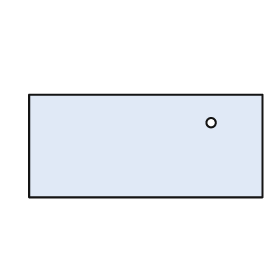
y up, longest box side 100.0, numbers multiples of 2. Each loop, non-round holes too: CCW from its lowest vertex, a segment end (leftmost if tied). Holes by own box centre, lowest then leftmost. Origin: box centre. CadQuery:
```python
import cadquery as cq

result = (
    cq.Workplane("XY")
    .moveTo(-50.0, -22.0)
    .lineTo(50.0, -22.0)
    .lineTo(50.0, 22.0)
    .lineTo(-50.0, 22.0)
    .close()
    .moveTo(28.0, 10.0)
    .circle(2.0)
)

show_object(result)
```